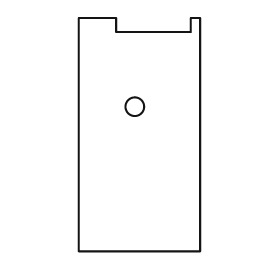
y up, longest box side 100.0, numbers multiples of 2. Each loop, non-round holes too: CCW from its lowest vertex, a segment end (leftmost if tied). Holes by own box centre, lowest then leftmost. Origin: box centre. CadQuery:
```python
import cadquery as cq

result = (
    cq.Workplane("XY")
    .moveTo(-26.0, -50.0)
    .lineTo(26.0, -50.0)
    .lineTo(26.0, 50.0)
    .lineTo(22.0, 50.0)
    .lineTo(22.0, 44.0)
    .lineTo(-10.0, 44.0)
    .lineTo(-10.0, 50.0)
    .lineTo(-26.0, 50.0)
    .close()
    .moveTo(-2.0, 12.0)
    .circle(4.0)
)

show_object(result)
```